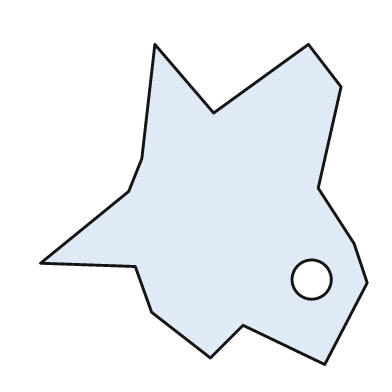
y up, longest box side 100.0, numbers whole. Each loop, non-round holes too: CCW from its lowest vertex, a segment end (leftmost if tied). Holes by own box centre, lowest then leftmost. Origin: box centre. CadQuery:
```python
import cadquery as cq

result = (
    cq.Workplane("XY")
    .moveTo(37.0, -49.0)
    .lineTo(50.0, -24.0)
    .lineTo(46.0, -12.0)
    .lineTo(35.0, 5.0)
    .lineTo(42.0, 36.0)
    .lineTo(32.0, 49.0)
    .lineTo(3.0, 28.0)
    .lineTo(-15.0, 49.0)
    .lineTo(-19.0, 14.0)
    .lineTo(-23.0, 4.0)
    .lineTo(-50.0, -18.0)
    .lineTo(-21.0, -19.0)
    .lineTo(-16.0, -33.0)
    .lineTo(2.0, -47.0)
    .lineTo(12.0, -37.0)
    .close()
    .moveTo(33.0, -23.0)
    .circle(6.0)
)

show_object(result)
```